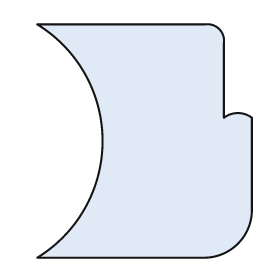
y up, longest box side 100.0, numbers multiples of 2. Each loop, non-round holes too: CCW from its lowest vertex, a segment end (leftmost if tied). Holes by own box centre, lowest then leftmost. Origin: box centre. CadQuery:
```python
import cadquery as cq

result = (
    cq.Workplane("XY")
    .moveTo(-46.0, -50.0)
    .lineTo(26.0, -50.0)
    .threePointArc((40.0, -44.0), (46.0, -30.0))
    .lineTo(46.0, 10.0)
    .threePointArc((40.0, 12.0), (34.0, 10.0))
    .lineTo(34.0, 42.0)
    .threePointArc((32.0, 48.0), (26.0, 50.0))
    .lineTo(-46.0, 50.0)
    .threePointArc((-18.0, 0.0), (-46.0, -50.0))
    .close()
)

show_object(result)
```